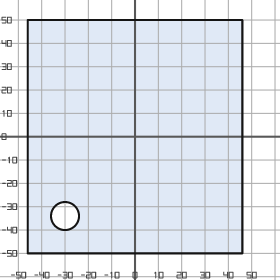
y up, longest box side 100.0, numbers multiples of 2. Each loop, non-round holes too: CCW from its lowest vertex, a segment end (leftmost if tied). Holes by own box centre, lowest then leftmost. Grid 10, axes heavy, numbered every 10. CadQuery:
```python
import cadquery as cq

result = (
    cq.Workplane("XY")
    .moveTo(-46.0, -50.0)
    .lineTo(46.0, -50.0)
    .lineTo(46.0, 50.0)
    .lineTo(-46.0, 50.0)
    .close()
    .moveTo(-30.0, -34.0)
    .circle(6.0)
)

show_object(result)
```